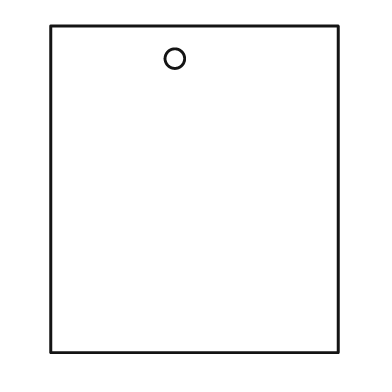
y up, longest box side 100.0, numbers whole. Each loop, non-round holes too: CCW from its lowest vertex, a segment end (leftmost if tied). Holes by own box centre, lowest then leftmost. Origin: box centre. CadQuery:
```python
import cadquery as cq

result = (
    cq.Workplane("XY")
    .moveTo(-44.0, -50.0)
    .lineTo(44.0, -50.0)
    .lineTo(44.0, 50.0)
    .lineTo(-44.0, 50.0)
    .close()
    .moveTo(-6.0, 40.0)
    .circle(3.0)
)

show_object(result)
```